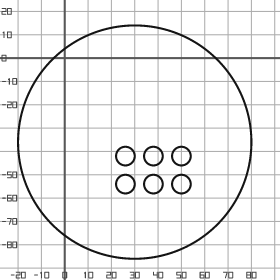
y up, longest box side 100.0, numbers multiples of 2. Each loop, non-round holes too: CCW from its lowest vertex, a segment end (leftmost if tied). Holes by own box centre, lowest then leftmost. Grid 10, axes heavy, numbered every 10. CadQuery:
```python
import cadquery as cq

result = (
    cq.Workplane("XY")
    .moveTo(30.0, -36.0)
    .circle(50.0)
    .moveTo(26.0, -54.0)
    .circle(4.0)
    .moveTo(38.0, -54.0)
    .circle(4.0)
    .moveTo(50.0, -54.0)
    .circle(4.0)
    .moveTo(26.0, -42.0)
    .circle(4.0)
    .moveTo(38.0, -42.0)
    .circle(4.0)
    .moveTo(50.0, -42.0)
    .circle(4.0)
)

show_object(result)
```